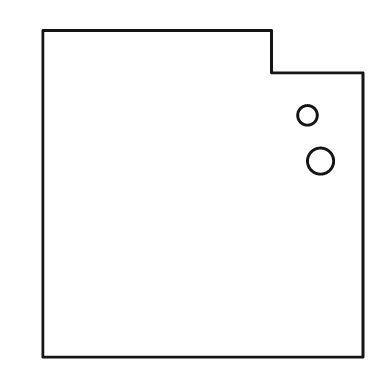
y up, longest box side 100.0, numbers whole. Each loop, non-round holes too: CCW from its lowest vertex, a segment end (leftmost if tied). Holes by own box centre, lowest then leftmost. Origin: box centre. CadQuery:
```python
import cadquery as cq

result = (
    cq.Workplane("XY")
    .moveTo(-49.0, -50.0)
    .lineTo(49.0, -50.0)
    .lineTo(49.0, 37.0)
    .lineTo(21.0, 37.0)
    .lineTo(21.0, 50.0)
    .lineTo(-49.0, 50.0)
    .close()
    .moveTo(36.0, 10.0)
    .circle(4.0)
    .moveTo(32.0, 24.0)
    .circle(3.0)
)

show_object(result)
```